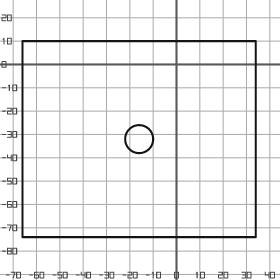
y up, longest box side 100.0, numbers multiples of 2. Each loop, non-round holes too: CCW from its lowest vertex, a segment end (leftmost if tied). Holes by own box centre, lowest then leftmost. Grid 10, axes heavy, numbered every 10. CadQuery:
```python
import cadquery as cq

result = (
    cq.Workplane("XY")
    .moveTo(-66.0, -74.0)
    .lineTo(34.0, -74.0)
    .lineTo(34.0, 10.0)
    .lineTo(-66.0, 10.0)
    .close()
    .moveTo(-16.0, -32.0)
    .circle(6.0)
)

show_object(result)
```